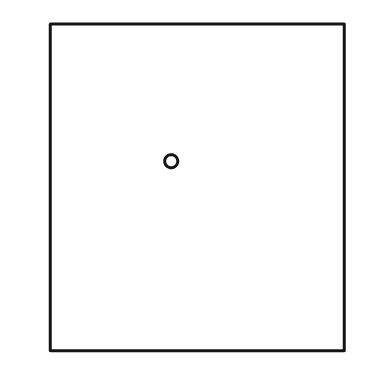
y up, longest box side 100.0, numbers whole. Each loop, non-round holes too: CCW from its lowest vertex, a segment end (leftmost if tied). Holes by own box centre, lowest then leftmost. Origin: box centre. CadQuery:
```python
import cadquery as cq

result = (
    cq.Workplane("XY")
    .moveTo(-45.0, -50.0)
    .lineTo(45.0, -50.0)
    .lineTo(45.0, 50.0)
    .lineTo(-45.0, 50.0)
    .close()
    .moveTo(-8.0, 8.0)
    .circle(2.0)
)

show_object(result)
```